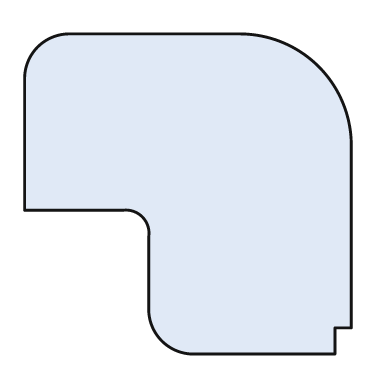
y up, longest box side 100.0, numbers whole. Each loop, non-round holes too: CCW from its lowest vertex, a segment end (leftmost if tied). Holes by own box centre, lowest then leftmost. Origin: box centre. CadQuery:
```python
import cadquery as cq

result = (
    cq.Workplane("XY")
    .moveTo(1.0, -49.0)
    .lineTo(45.0, -49.0)
    .lineTo(45.0, -41.0)
    .lineTo(50.0, -41.0)
    .lineTo(50.0, 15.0)
    .threePointArc((40.0, 39.0), (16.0, 49.0))
    .lineTo(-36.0, 49.0)
    .threePointArc((-46.0, 45.0), (-50.0, 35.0))
    .lineTo(-50.0, -5.0)
    .lineTo(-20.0, -5.0)
    .threePointArc((-14.0, -7.0), (-12.0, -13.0))
    .lineTo(-12.0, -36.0)
    .threePointArc((-8.0, -45.0), (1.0, -49.0))
    .close()
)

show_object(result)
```